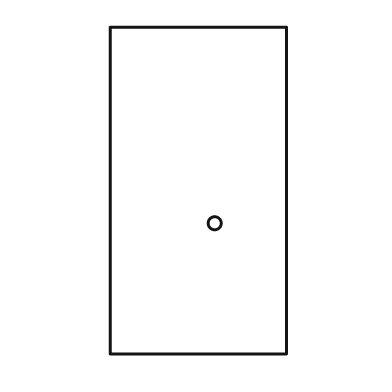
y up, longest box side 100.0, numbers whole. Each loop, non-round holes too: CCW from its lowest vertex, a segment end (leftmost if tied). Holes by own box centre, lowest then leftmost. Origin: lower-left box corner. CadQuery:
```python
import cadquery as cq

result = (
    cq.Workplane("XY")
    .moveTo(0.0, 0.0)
    .lineTo(54.0, 0.0)
    .lineTo(54.0, 100.0)
    .lineTo(0.0, 100.0)
    .close()
    .moveTo(32.0, 40.0)
    .circle(2.0)
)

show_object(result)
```